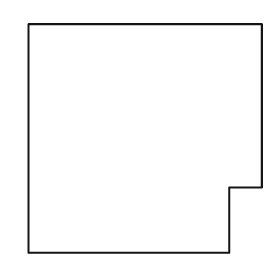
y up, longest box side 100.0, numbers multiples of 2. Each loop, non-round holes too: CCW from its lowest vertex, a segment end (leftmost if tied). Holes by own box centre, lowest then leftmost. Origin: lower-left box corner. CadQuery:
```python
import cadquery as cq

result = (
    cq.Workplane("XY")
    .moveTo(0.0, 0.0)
    .lineTo(86.0, 0.0)
    .lineTo(86.0, 28.0)
    .lineTo(100.0, 28.0)
    .lineTo(100.0, 98.0)
    .lineTo(0.0, 98.0)
    .close()
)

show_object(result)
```